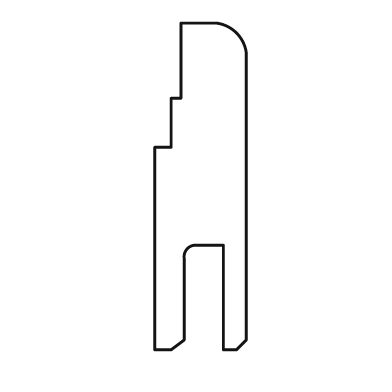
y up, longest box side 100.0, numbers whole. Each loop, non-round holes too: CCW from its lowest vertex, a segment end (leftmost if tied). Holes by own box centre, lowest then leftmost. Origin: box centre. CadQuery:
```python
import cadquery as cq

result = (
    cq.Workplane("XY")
    .moveTo(-14.0, -50.0)
    .lineTo(-9.0, -50.0)
    .lineTo(-5.0, -47.0)
    .lineTo(-5.0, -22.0)
    .threePointArc((-4.0, -19.0), (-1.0, -18.0))
    .lineTo(7.0, -18.0)
    .lineTo(7.0, -50.0)
    .lineTo(11.0, -50.0)
    .lineTo(14.0, -47.0)
    .lineTo(14.0, 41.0)
    .threePointArc((11.0, 47.0), (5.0, 50.0))
    .lineTo(-6.0, 50.0)
    .lineTo(-6.0, 27.0)
    .lineTo(-9.0, 27.0)
    .lineTo(-9.0, 12.0)
    .lineTo(-14.0, 12.0)
    .close()
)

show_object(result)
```